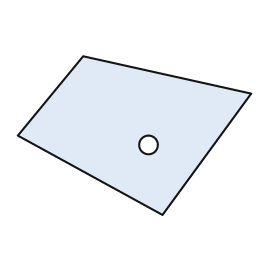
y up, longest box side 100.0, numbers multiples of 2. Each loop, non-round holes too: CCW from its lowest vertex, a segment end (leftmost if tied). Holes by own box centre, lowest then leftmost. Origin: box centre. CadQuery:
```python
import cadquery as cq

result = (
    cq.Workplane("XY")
    .moveTo(12.0, -34.0)
    .lineTo(50.0, 18.0)
    .lineTo(-22.0, 34.0)
    .lineTo(-50.0, 0.0)
    .close()
    .moveTo(6.0, -4.0)
    .circle(4.0)
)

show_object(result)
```